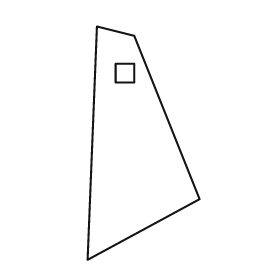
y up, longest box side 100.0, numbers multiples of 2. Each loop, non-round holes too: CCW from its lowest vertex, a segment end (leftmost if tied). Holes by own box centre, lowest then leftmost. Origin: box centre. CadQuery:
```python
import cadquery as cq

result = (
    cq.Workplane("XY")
    .moveTo(-24.0, -50.0)
    .lineTo(24.0, -24.0)
    .lineTo(-4.0, 46.0)
    .lineTo(-20.0, 50.0)
    .close()
    .moveTo(-12.0, 26.0)
    .lineTo(-4.0, 26.0)
    .lineTo(-4.0, 34.0)
    .lineTo(-12.0, 34.0)
    .close()
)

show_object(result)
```